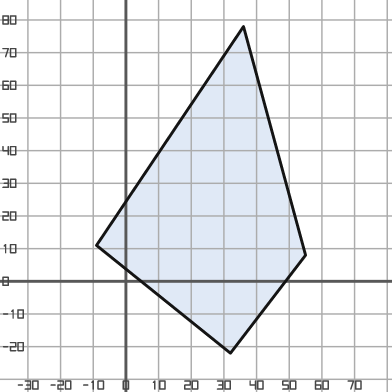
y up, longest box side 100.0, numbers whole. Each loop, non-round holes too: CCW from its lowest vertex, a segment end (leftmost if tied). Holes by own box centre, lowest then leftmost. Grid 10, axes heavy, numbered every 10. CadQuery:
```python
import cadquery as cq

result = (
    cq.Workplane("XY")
    .moveTo(32.0, -22.0)
    .lineTo(55.0, 8.0)
    .lineTo(36.0, 78.0)
    .lineTo(-9.0, 11.0)
    .close()
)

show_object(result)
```